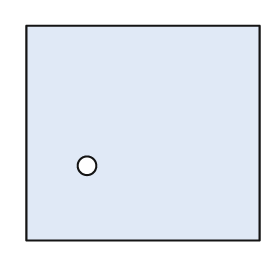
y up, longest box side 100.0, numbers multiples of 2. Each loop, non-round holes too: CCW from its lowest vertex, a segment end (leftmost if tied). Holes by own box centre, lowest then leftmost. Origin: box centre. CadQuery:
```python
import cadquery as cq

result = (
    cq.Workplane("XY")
    .moveTo(-50.0, -46.0)
    .lineTo(50.0, -46.0)
    .lineTo(50.0, 46.0)
    .lineTo(-50.0, 46.0)
    .close()
    .moveTo(-24.0, -14.0)
    .circle(4.0)
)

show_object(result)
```